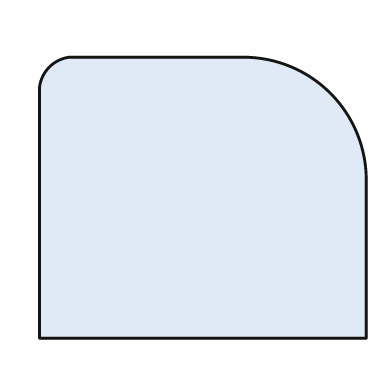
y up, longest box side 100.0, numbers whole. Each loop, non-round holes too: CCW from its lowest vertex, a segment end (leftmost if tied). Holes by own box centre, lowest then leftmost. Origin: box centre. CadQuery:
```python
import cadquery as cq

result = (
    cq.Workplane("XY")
    .moveTo(-50.0, -43.0)
    .lineTo(50.0, -43.0)
    .lineTo(50.0, 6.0)
    .threePointArc((39.0, 32.0), (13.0, 43.0))
    .lineTo(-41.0, 43.0)
    .threePointArc((-47.0, 40.0), (-50.0, 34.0))
    .close()
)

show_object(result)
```